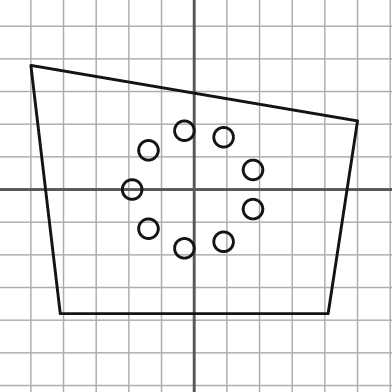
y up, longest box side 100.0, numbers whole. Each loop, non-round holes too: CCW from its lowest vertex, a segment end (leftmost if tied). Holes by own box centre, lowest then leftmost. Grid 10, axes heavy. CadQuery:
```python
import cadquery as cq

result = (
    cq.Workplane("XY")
    .moveTo(-41.0, -38.0)
    .lineTo(41.0, -38.0)
    .lineTo(50.0, 21.0)
    .lineTo(-50.0, 38.0)
    .close()
    .moveTo(-3.0, -18.0)
    .circle(3.0)
    .moveTo(9.0, -16.0)
    .circle(3.0)
    .moveTo(-14.0, -12.0)
    .circle(3.0)
    .moveTo(18.0, -6.0)
    .circle(3.0)
    .moveTo(-19.0, 0.0)
    .circle(3.0)
    .moveTo(18.0, 6.0)
    .circle(3.0)
    .moveTo(-14.0, 12.0)
    .circle(3.0)
    .moveTo(9.0, 16.0)
    .circle(3.0)
    .moveTo(-3.0, 18.0)
    .circle(3.0)
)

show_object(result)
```